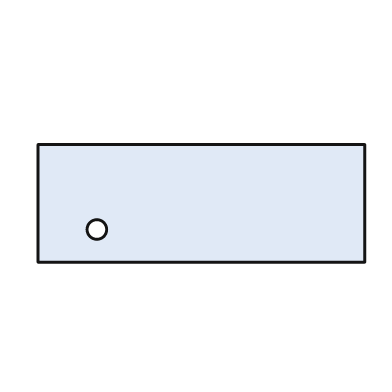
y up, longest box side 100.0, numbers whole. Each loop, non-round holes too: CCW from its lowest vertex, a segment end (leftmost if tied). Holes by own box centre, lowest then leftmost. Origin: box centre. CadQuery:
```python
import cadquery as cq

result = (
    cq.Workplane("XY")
    .moveTo(-50.0, -18.0)
    .lineTo(50.0, -18.0)
    .lineTo(50.0, 18.0)
    .lineTo(-50.0, 18.0)
    .close()
    .moveTo(-32.0, -8.0)
    .circle(3.0)
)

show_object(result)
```